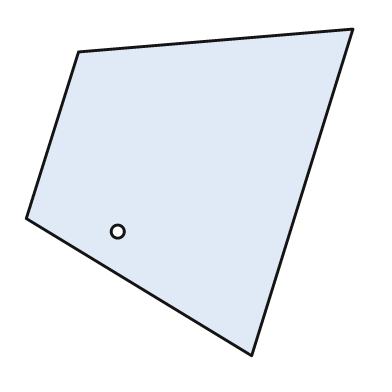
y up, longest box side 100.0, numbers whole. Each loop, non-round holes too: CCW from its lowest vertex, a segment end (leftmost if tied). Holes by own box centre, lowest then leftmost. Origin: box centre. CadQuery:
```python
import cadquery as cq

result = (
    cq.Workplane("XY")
    .moveTo(19.0, -50.0)
    .lineTo(50.0, 50.0)
    .lineTo(-34.0, 43.0)
    .lineTo(-50.0, -8.0)
    .close()
    .moveTo(-22.0, -12.0)
    .circle(2.0)
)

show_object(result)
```